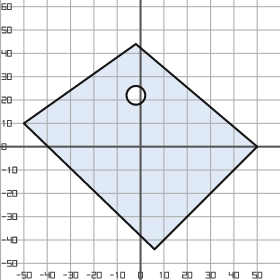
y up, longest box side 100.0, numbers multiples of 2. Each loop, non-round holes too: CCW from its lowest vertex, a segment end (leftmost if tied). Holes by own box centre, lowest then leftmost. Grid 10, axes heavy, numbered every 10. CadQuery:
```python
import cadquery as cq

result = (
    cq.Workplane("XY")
    .moveTo(6.0, -44.0)
    .lineTo(50.0, 0.0)
    .lineTo(-2.0, 44.0)
    .lineTo(-50.0, 10.0)
    .close()
    .moveTo(-2.0, 22.0)
    .circle(4.0)
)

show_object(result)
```